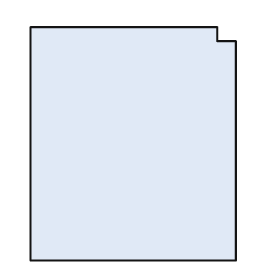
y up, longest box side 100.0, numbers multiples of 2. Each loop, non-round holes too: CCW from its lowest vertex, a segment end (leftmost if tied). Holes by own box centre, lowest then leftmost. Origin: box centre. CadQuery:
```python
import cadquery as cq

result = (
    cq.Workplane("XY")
    .moveTo(-44.0, -50.0)
    .lineTo(44.0, -50.0)
    .lineTo(44.0, 44.0)
    .lineTo(36.0, 44.0)
    .lineTo(36.0, 50.0)
    .lineTo(-44.0, 50.0)
    .close()
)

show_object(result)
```